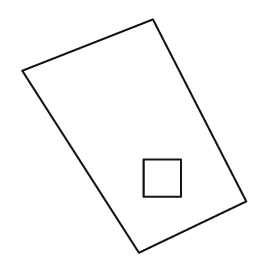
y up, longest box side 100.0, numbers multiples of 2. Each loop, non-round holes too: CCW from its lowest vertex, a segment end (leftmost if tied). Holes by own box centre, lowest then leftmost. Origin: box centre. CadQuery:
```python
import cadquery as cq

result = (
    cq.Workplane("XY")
    .moveTo(2.0, -50.0)
    .lineTo(48.0, -28.0)
    .lineTo(8.0, 50.0)
    .lineTo(-48.0, 28.0)
    .close()
    .moveTo(4.0, -26.0)
    .lineTo(20.0, -26.0)
    .lineTo(20.0, -10.0)
    .lineTo(4.0, -10.0)
    .close()
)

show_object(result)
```